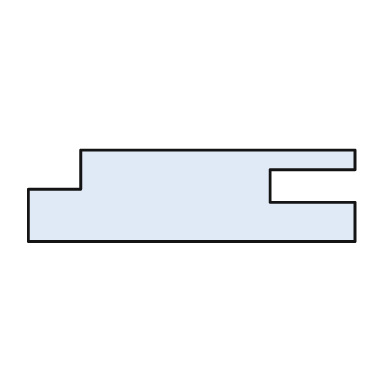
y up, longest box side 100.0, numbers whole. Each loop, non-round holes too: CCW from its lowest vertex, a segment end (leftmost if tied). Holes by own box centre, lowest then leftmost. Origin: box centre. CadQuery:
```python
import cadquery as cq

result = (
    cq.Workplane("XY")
    .moveTo(-50.0, -14.0)
    .lineTo(50.0, -14.0)
    .lineTo(50.0, -2.0)
    .lineTo(24.0, -2.0)
    .lineTo(24.0, 8.0)
    .lineTo(50.0, 8.0)
    .lineTo(50.0, 14.0)
    .lineTo(-34.0, 14.0)
    .lineTo(-34.0, 2.0)
    .lineTo(-50.0, 2.0)
    .close()
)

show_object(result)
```